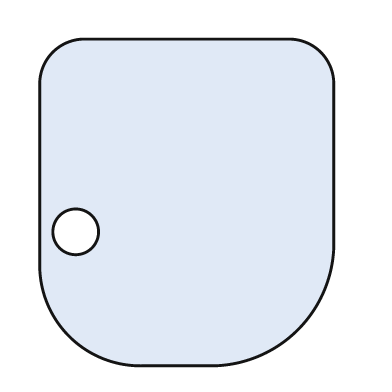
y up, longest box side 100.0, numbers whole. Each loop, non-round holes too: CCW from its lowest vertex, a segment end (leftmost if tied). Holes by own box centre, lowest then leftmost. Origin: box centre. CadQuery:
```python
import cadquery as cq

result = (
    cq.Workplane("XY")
    .moveTo(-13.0, -50.0)
    .lineTo(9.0, -50.0)
    .threePointArc((34.0, -39.0), (45.0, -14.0))
    .lineTo(45.0, 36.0)
    .threePointArc((41.0, 46.0), (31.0, 50.0))
    .lineTo(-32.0, 50.0)
    .threePointArc((-41.0, 46.0), (-45.0, 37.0))
    .lineTo(-45.0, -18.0)
    .threePointArc((-36.0, -41.0), (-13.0, -50.0))
    .close()
    .moveTo(-34.0, -9.0)
    .circle(7.0)
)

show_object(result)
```